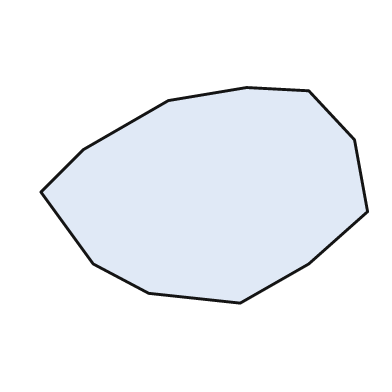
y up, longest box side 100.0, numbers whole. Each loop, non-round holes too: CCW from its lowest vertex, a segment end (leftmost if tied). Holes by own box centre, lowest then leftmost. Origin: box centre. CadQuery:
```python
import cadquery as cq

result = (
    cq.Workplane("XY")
    .moveTo(11.0, -33.0)
    .lineTo(32.0, -21.0)
    .lineTo(50.0, -5.0)
    .lineTo(46.0, 17.0)
    .lineTo(32.0, 32.0)
    .lineTo(13.0, 33.0)
    .lineTo(-11.0, 29.0)
    .lineTo(-37.0, 14.0)
    .lineTo(-50.0, 1.0)
    .lineTo(-34.0, -21.0)
    .lineTo(-17.0, -30.0)
    .close()
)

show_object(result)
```